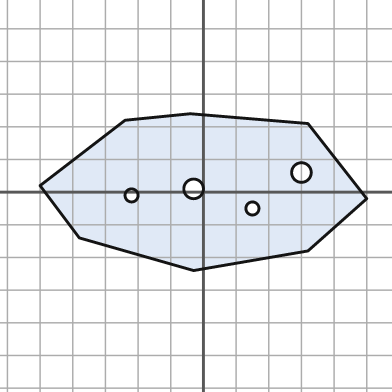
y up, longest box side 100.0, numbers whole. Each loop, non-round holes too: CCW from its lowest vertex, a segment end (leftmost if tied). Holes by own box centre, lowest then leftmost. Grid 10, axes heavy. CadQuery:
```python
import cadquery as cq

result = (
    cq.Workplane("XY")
    .moveTo(-3.0, -24.0)
    .lineTo(32.0, -18.0)
    .lineTo(50.0, -2.0)
    .lineTo(32.0, 21.0)
    .lineTo(-4.0, 24.0)
    .lineTo(-24.0, 22.0)
    .lineTo(-50.0, 2.0)
    .lineTo(-38.0, -14.0)
    .close()
    .moveTo(15.0, -5.0)
    .circle(2.0)
    .moveTo(-22.0, -1.0)
    .circle(2.0)
    .moveTo(-3.0, 1.0)
    .circle(3.0)
    .moveTo(30.0, 6.0)
    .circle(3.0)
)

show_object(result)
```